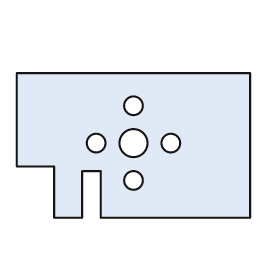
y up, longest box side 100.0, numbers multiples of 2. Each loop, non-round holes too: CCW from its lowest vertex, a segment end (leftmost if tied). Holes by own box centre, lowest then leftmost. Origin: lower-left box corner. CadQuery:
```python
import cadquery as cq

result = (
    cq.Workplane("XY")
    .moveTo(16.0, 0.0)
    .lineTo(28.0, 0.0)
    .lineTo(28.0, 20.0)
    .lineTo(36.0, 20.0)
    .lineTo(36.0, 0.0)
    .lineTo(100.0, 0.0)
    .lineTo(100.0, 62.0)
    .lineTo(0.0, 62.0)
    .lineTo(0.0, 22.0)
    .lineTo(16.0, 22.0)
    .close()
    .moveTo(50.0, 16.0)
    .circle(4.0)
    .moveTo(34.0, 32.0)
    .circle(4.0)
    .moveTo(50.0, 32.0)
    .circle(6.0)
    .moveTo(66.0, 32.0)
    .circle(4.0)
    .moveTo(50.0, 48.0)
    .circle(4.0)
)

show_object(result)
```